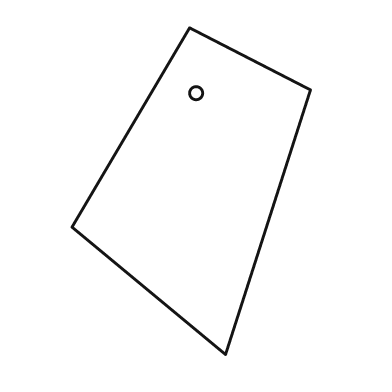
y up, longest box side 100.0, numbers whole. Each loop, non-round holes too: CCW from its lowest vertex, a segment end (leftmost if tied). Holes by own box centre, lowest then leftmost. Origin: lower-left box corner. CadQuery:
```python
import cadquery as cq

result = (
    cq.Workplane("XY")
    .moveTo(47.0, 0.0)
    .lineTo(73.0, 81.0)
    .lineTo(36.0, 100.0)
    .lineTo(0.0, 39.0)
    .close()
    .moveTo(38.0, 80.0)
    .circle(2.0)
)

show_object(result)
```